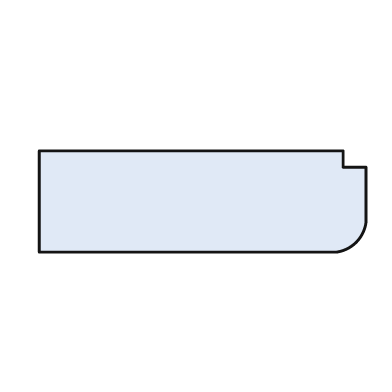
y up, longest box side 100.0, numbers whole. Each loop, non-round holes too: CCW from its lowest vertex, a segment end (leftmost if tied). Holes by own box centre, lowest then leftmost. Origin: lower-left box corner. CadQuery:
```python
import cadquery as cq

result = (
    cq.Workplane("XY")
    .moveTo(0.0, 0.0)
    .lineTo(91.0, 0.0)
    .threePointArc((97.0, 3.0), (100.0, 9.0))
    .lineTo(100.0, 26.0)
    .lineTo(93.0, 26.0)
    .lineTo(93.0, 31.0)
    .lineTo(0.0, 31.0)
    .close()
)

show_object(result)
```